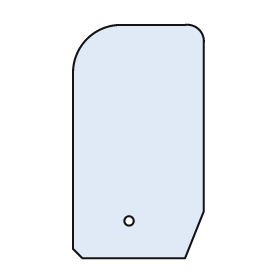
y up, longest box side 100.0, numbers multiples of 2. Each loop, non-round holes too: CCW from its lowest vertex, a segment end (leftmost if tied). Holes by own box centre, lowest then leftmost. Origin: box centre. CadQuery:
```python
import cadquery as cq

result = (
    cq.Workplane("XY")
    .moveTo(-24.0, -50.0)
    .lineTo(20.0, -50.0)
    .lineTo(28.0, -30.0)
    .lineTo(28.0, 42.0)
    .threePointArc((26.0, 48.0), (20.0, 50.0))
    .lineTo(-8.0, 50.0)
    .threePointArc((-22.0, 44.0), (-28.0, 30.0))
    .lineTo(-28.0, -46.0)
    .close()
    .moveTo(-4.0, -34.0)
    .circle(2.0)
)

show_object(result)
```